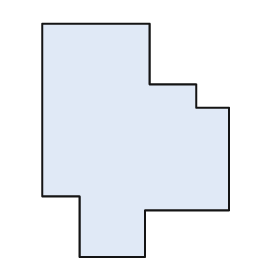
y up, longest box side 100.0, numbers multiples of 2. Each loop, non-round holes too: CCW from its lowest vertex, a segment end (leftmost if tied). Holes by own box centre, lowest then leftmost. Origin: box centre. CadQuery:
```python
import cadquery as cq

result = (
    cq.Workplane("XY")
    .moveTo(-24.0, -50.0)
    .lineTo(4.0, -50.0)
    .lineTo(4.0, -30.0)
    .lineTo(40.0, -30.0)
    .lineTo(40.0, 14.0)
    .lineTo(26.0, 14.0)
    .lineTo(26.0, 24.0)
    .lineTo(6.0, 24.0)
    .lineTo(6.0, 50.0)
    .lineTo(-40.0, 50.0)
    .lineTo(-40.0, -24.0)
    .lineTo(-24.0, -24.0)
    .close()
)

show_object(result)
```